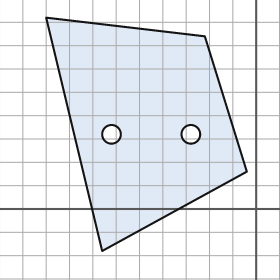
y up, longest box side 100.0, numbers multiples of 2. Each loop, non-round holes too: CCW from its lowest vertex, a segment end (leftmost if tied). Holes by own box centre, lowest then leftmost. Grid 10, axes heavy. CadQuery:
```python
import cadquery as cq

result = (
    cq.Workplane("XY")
    .moveTo(-66.0, -18.0)
    .lineTo(-4.0, 16.0)
    .lineTo(-22.0, 74.0)
    .lineTo(-90.0, 82.0)
    .close()
    .moveTo(-62.0, 32.0)
    .circle(4.0)
    .moveTo(-28.0, 32.0)
    .circle(4.0)
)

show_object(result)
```